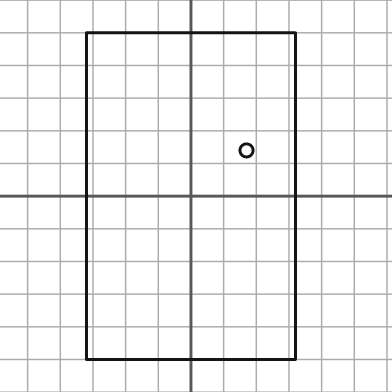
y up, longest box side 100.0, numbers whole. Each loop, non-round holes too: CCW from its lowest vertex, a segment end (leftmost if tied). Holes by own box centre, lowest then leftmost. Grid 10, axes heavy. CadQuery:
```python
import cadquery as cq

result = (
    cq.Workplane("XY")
    .moveTo(-32.0, -50.0)
    .lineTo(32.0, -50.0)
    .lineTo(32.0, 50.0)
    .lineTo(-32.0, 50.0)
    .close()
    .moveTo(17.0, 14.0)
    .circle(2.0)
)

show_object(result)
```